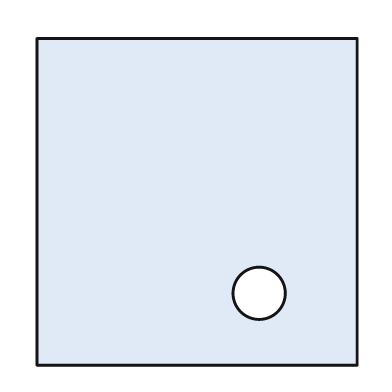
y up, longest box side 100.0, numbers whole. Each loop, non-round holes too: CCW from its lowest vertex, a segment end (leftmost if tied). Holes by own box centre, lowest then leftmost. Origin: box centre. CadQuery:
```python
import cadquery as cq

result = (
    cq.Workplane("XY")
    .moveTo(-49.0, -50.0)
    .lineTo(49.0, -50.0)
    .lineTo(49.0, 50.0)
    .lineTo(-49.0, 50.0)
    .close()
    .moveTo(19.0, -28.0)
    .circle(8.0)
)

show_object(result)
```